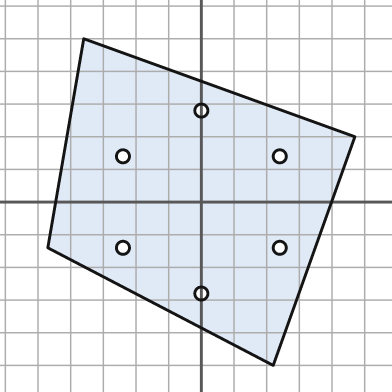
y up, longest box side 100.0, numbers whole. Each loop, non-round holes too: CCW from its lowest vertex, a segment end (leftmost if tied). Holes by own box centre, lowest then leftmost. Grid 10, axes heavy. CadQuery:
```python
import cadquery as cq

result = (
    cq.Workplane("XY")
    .moveTo(22.0, -50.0)
    .lineTo(47.0, 20.0)
    .lineTo(-36.0, 50.0)
    .lineTo(-47.0, -14.0)
    .close()
    .moveTo(0.0, -28.0)
    .circle(2.0)
    .moveTo(-24.0, -14.0)
    .circle(2.0)
    .moveTo(24.0, -14.0)
    .circle(2.0)
    .moveTo(-24.0, 14.0)
    .circle(2.0)
    .moveTo(24.0, 14.0)
    .circle(2.0)
    .moveTo(0.0, 28.0)
    .circle(2.0)
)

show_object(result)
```